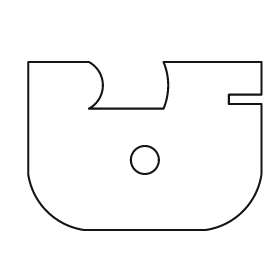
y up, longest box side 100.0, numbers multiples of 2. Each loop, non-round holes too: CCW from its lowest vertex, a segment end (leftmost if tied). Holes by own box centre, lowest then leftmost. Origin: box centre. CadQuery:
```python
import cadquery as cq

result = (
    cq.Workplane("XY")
    .moveTo(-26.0, -36.0)
    .lineTo(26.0, -36.0)
    .threePointArc((42.0, -28.0), (50.0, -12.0))
    .lineTo(50.0, 18.0)
    .lineTo(36.0, 18.0)
    .lineTo(36.0, 22.0)
    .lineTo(50.0, 22.0)
    .lineTo(50.0, 36.0)
    .lineTo(8.0, 36.0)
    .threePointArc((10.0, 26.0), (8.0, 16.0))
    .lineTo(-24.0, 16.0)
    .threePointArc((-18.0, 26.0), (-24.0, 36.0))
    .lineTo(-50.0, 36.0)
    .lineTo(-50.0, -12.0)
    .threePointArc((-42.0, -28.0), (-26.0, -36.0))
    .close()
    .moveTo(0.0, -6.0)
    .circle(6.0)
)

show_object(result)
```